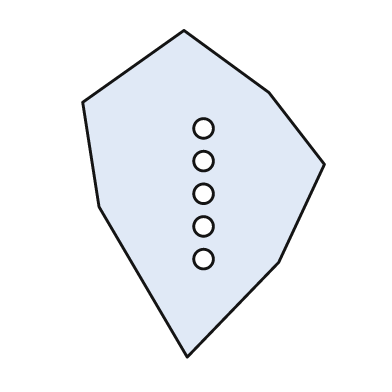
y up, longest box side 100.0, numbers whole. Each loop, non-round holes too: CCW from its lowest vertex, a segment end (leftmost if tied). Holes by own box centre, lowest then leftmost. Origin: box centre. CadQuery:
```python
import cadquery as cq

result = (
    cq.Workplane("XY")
    .moveTo(-5.0, -50.0)
    .lineTo(23.0, -21.0)
    .lineTo(37.0, 9.0)
    .lineTo(20.0, 31.0)
    .lineTo(-6.0, 50.0)
    .lineTo(-37.0, 28.0)
    .lineTo(-32.0, -4.0)
    .close()
    .moveTo(0.0, -20.0)
    .circle(3.0)
    .moveTo(0.0, -10.0)
    .circle(3.0)
    .moveTo(0.0, 0.0)
    .circle(3.0)
    .moveTo(0.0, 10.0)
    .circle(3.0)
    .moveTo(0.0, 20.0)
    .circle(3.0)
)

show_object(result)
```